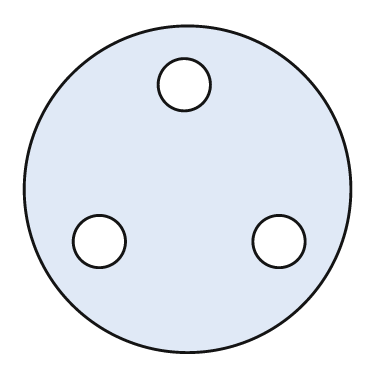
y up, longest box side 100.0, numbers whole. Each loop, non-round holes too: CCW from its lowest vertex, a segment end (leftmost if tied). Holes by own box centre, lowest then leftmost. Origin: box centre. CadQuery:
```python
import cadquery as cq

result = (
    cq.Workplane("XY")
    .moveTo(0.0, 0.0)
    .circle(50.0)
    .moveTo(-27.0, -16.0)
    .circle(8.0)
    .moveTo(28.0, -16.0)
    .circle(8.0)
    .moveTo(-1.0, 32.0)
    .circle(8.0)
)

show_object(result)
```